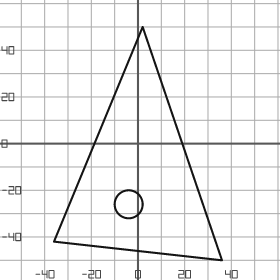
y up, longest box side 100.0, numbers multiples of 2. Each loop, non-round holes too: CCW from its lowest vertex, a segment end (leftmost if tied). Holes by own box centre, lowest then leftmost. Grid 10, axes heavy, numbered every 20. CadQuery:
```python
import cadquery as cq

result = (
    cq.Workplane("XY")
    .moveTo(36.0, -50.0)
    .lineTo(2.0, 50.0)
    .lineTo(-36.0, -42.0)
    .close()
    .moveTo(-4.0, -26.0)
    .circle(6.0)
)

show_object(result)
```